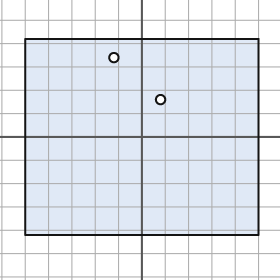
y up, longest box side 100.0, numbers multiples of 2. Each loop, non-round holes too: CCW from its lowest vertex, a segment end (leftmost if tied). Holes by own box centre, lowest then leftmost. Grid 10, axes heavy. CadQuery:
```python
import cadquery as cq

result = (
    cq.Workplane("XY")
    .moveTo(-50.0, -42.0)
    .lineTo(50.0, -42.0)
    .lineTo(50.0, 42.0)
    .lineTo(-50.0, 42.0)
    .close()
    .moveTo(8.0, 16.0)
    .circle(2.0)
    .moveTo(-12.0, 34.0)
    .circle(2.0)
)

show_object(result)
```